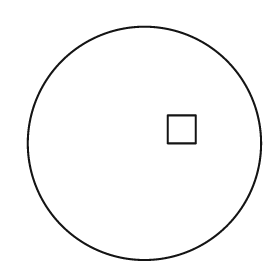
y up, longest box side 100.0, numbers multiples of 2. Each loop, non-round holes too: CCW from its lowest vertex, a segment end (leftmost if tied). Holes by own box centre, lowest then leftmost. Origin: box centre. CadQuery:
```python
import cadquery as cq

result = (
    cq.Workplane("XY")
    .moveTo(0.0, 0.0)
    .circle(50.0)
    .moveTo(10.0, 0.0)
    .lineTo(22.0, 0.0)
    .lineTo(22.0, 12.0)
    .lineTo(10.0, 12.0)
    .close()
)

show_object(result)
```